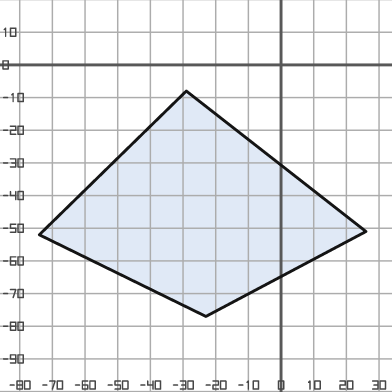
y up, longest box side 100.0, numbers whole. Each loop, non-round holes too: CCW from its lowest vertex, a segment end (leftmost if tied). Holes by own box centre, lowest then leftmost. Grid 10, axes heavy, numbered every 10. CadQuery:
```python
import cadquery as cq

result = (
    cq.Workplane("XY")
    .moveTo(-23.0, -77.0)
    .lineTo(26.0, -51.0)
    .lineTo(-29.0, -8.0)
    .lineTo(-74.0, -52.0)
    .close()
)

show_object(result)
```